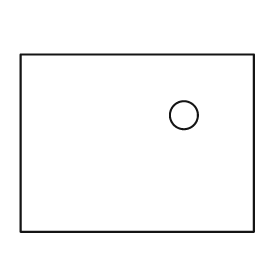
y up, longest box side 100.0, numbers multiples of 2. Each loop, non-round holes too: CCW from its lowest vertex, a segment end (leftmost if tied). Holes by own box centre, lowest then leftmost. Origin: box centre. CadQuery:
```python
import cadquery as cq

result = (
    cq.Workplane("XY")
    .moveTo(-50.0, -38.0)
    .lineTo(50.0, -38.0)
    .lineTo(50.0, 38.0)
    .lineTo(-50.0, 38.0)
    .close()
    .moveTo(20.0, 12.0)
    .circle(6.0)
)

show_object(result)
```